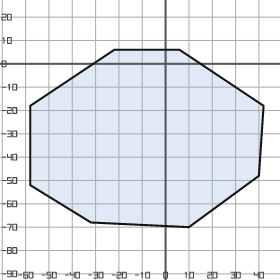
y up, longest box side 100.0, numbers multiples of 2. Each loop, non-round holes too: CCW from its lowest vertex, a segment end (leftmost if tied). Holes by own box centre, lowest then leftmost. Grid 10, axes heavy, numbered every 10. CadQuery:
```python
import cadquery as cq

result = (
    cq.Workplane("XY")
    .moveTo(10.0, -70.0)
    .lineTo(40.0, -48.0)
    .lineTo(42.0, -18.0)
    .lineTo(6.0, 6.0)
    .lineTo(-22.0, 6.0)
    .lineTo(-58.0, -18.0)
    .lineTo(-58.0, -52.0)
    .lineTo(-32.0, -68.0)
    .close()
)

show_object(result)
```